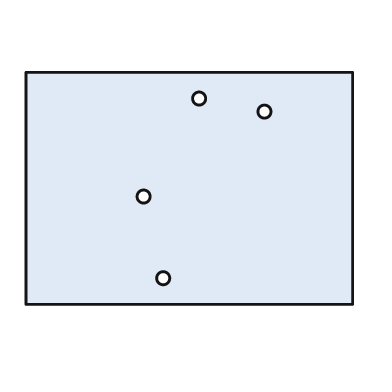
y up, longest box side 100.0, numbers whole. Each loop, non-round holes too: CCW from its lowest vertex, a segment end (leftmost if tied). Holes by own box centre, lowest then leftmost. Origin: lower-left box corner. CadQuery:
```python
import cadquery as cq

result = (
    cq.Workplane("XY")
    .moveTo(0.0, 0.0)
    .lineTo(100.0, 0.0)
    .lineTo(100.0, 71.0)
    .lineTo(0.0, 71.0)
    .close()
    .moveTo(42.0, 8.0)
    .circle(2.0)
    .moveTo(36.0, 33.0)
    .circle(2.0)
    .moveTo(73.0, 59.0)
    .circle(2.0)
    .moveTo(53.0, 63.0)
    .circle(2.0)
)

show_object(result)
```